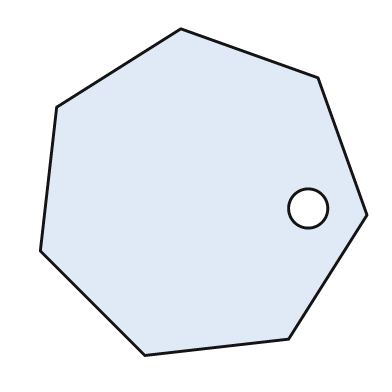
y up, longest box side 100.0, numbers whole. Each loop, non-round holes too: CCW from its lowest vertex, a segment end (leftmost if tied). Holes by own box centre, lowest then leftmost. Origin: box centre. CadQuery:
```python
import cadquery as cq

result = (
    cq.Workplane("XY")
    .moveTo(-18.0, -50.0)
    .lineTo(26.0, -45.0)
    .lineTo(50.0, -7.0)
    .lineTo(35.0, 35.0)
    .lineTo(-7.0, 50.0)
    .lineTo(-45.0, 26.0)
    .lineTo(-50.0, -18.0)
    .close()
    .moveTo(32.0, -5.0)
    .circle(6.0)
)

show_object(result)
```